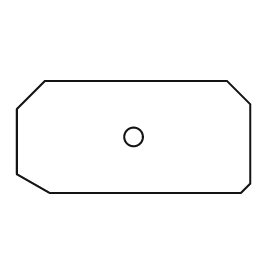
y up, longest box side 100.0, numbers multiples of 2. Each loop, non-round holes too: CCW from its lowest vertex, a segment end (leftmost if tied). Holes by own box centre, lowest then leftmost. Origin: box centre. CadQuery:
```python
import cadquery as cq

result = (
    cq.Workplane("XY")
    .moveTo(-36.0, -24.0)
    .lineTo(46.0, -24.0)
    .lineTo(50.0, -20.0)
    .lineTo(50.0, 14.0)
    .lineTo(40.0, 24.0)
    .lineTo(-38.0, 24.0)
    .lineTo(-50.0, 12.0)
    .lineTo(-50.0, -16.0)
    .close()
    .moveTo(0.0, 0.0)
    .circle(4.0)
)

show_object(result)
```